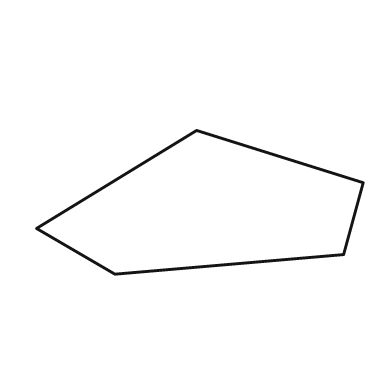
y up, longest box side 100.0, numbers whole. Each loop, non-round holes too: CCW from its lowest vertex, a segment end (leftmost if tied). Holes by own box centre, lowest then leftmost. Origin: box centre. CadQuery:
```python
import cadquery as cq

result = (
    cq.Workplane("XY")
    .moveTo(-26.0, -22.0)
    .lineTo(44.0, -16.0)
    .lineTo(50.0, 6.0)
    .lineTo(-1.0, 22.0)
    .lineTo(-50.0, -8.0)
    .close()
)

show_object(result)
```